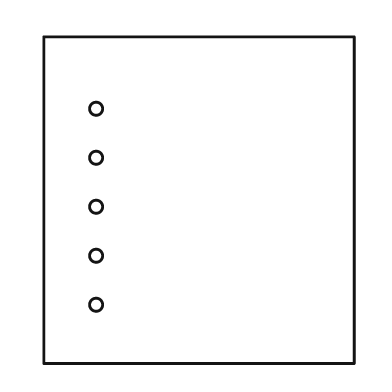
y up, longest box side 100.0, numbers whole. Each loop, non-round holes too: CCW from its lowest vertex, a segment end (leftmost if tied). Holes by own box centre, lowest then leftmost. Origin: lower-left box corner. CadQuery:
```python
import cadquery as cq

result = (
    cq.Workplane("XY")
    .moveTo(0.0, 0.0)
    .lineTo(95.0, 0.0)
    .lineTo(95.0, 100.0)
    .lineTo(0.0, 100.0)
    .close()
    .moveTo(16.0, 18.0)
    .circle(2.0)
    .moveTo(16.0, 33.0)
    .circle(2.0)
    .moveTo(16.0, 48.0)
    .circle(2.0)
    .moveTo(16.0, 63.0)
    .circle(2.0)
    .moveTo(16.0, 78.0)
    .circle(2.0)
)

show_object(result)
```